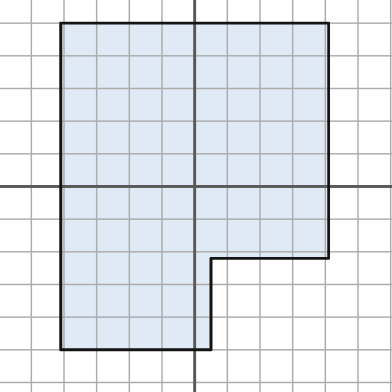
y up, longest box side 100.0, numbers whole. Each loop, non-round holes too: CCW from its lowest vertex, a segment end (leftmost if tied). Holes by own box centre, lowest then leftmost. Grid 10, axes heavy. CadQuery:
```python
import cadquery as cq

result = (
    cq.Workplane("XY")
    .moveTo(-41.0, -50.0)
    .lineTo(5.0, -50.0)
    .lineTo(5.0, -22.0)
    .lineTo(41.0, -22.0)
    .lineTo(41.0, 50.0)
    .lineTo(-41.0, 50.0)
    .close()
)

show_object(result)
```